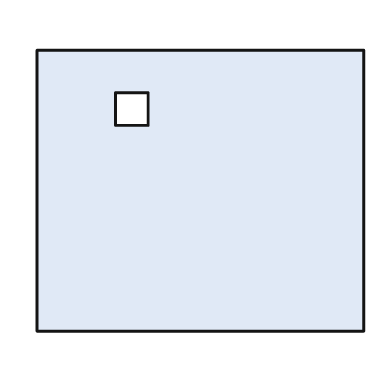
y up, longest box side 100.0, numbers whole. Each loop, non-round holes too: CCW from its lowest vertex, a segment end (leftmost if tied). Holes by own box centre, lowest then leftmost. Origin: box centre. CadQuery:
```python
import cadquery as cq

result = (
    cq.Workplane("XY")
    .moveTo(-50.0, -43.0)
    .lineTo(50.0, -43.0)
    .lineTo(50.0, 43.0)
    .lineTo(-50.0, 43.0)
    .close()
    .moveTo(-26.0, 20.0)
    .lineTo(-16.0, 20.0)
    .lineTo(-16.0, 30.0)
    .lineTo(-26.0, 30.0)
    .close()
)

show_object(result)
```